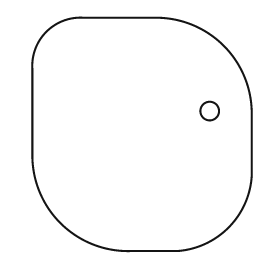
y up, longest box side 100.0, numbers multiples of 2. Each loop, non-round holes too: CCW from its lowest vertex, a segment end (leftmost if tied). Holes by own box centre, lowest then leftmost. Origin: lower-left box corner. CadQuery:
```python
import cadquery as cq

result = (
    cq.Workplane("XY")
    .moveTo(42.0, 0.0)
    .lineTo(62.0, 0.0)
    .threePointArc((84.0, 10.0), (94.0, 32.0))
    .lineTo(94.0, 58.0)
    .threePointArc((82.0, 88.0), (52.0, 100.0))
    .lineTo(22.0, 100.0)
    .threePointArc((6.0, 94.0), (0.0, 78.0))
    .lineTo(0.0, 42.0)
    .threePointArc((12.0, 12.0), (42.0, 0.0))
    .close()
    .moveTo(76.0, 60.0)
    .circle(4.0)
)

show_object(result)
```